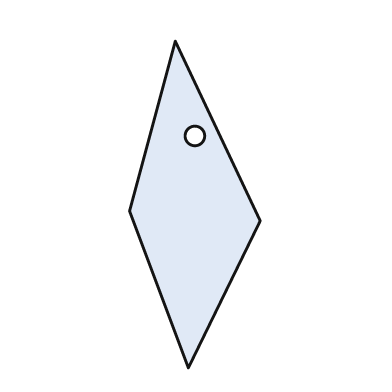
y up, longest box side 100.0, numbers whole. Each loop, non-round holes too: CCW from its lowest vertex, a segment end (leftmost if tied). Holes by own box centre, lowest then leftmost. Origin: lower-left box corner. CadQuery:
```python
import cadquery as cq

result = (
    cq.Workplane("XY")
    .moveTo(18.0, 0.0)
    .lineTo(40.0, 45.0)
    .lineTo(14.0, 100.0)
    .lineTo(0.0, 48.0)
    .close()
    .moveTo(20.0, 71.0)
    .circle(3.0)
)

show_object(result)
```